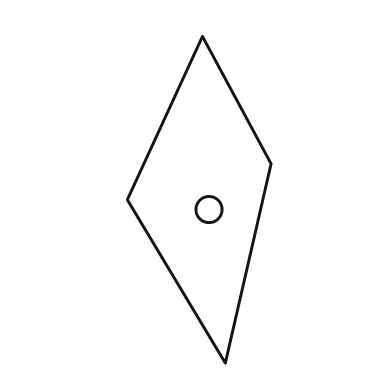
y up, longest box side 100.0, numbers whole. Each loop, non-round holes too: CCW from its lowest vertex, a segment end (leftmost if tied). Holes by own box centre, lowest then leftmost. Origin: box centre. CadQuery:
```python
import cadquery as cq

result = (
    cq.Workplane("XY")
    .moveTo(8.0, -50.0)
    .lineTo(22.0, 11.0)
    .lineTo(1.0, 50.0)
    .lineTo(-22.0, 0.0)
    .close()
    .moveTo(3.0, -3.0)
    .circle(4.0)
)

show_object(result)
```